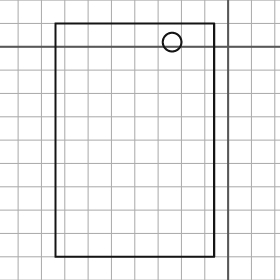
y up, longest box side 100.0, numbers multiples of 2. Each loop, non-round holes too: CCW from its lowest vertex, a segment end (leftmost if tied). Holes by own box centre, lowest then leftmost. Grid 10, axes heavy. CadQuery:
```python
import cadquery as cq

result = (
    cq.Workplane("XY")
    .moveTo(-74.0, -90.0)
    .lineTo(-6.0, -90.0)
    .lineTo(-6.0, 10.0)
    .lineTo(-74.0, 10.0)
    .close()
    .moveTo(-24.0, 2.0)
    .circle(4.0)
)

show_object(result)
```